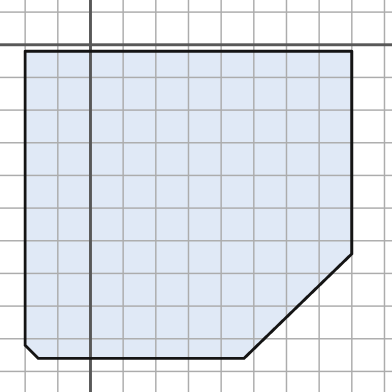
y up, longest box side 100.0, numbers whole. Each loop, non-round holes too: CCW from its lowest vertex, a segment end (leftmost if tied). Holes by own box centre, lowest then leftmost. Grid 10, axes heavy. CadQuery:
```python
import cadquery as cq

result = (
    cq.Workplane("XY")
    .moveTo(-16.0, -96.0)
    .lineTo(47.0, -96.0)
    .lineTo(80.0, -64.0)
    .lineTo(80.0, -2.0)
    .lineTo(-20.0, -2.0)
    .lineTo(-20.0, -92.0)
    .close()
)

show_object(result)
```